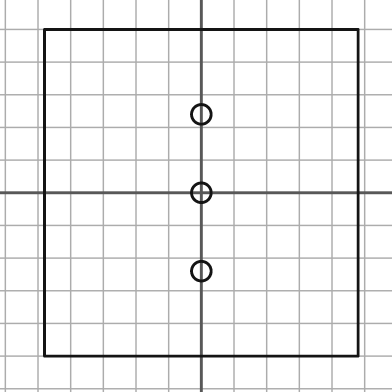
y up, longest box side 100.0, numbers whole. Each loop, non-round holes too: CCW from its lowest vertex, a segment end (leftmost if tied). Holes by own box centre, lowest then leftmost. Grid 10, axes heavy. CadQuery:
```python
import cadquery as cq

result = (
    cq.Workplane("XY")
    .moveTo(-48.0, -50.0)
    .lineTo(48.0, -50.0)
    .lineTo(48.0, 50.0)
    .lineTo(-48.0, 50.0)
    .close()
    .moveTo(0.0, -24.0)
    .circle(3.0)
    .moveTo(0.0, 0.0)
    .circle(3.0)
    .moveTo(0.0, 24.0)
    .circle(3.0)
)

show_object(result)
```